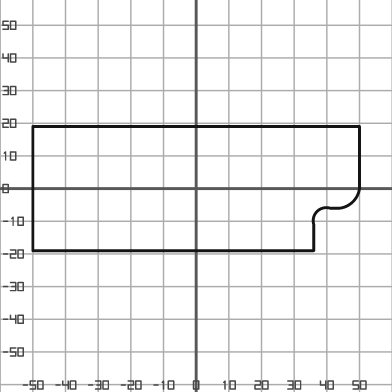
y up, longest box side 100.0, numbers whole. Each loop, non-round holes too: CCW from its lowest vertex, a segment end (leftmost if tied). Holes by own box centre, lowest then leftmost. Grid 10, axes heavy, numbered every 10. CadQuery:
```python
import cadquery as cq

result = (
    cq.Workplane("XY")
    .moveTo(-50.0, -19.0)
    .lineTo(36.0, -19.0)
    .lineTo(36.0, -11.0)
    .threePointArc((37.0, -7.0), (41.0, -6.0))
    .lineTo(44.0, -6.0)
    .threePointArc((48.0, -4.0), (50.0, 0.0))
    .lineTo(50.0, 19.0)
    .lineTo(-50.0, 19.0)
    .close()
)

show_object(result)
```